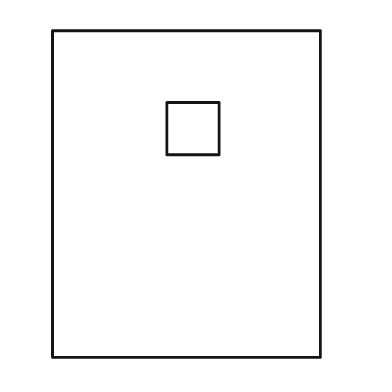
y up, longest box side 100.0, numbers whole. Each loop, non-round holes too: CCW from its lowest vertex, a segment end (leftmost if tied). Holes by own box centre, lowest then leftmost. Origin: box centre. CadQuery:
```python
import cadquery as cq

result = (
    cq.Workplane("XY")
    .moveTo(-41.0, -50.0)
    .lineTo(41.0, -50.0)
    .lineTo(41.0, 50.0)
    .lineTo(-41.0, 50.0)
    .close()
    .moveTo(-6.0, 12.0)
    .lineTo(10.0, 12.0)
    .lineTo(10.0, 28.0)
    .lineTo(-6.0, 28.0)
    .close()
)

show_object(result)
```